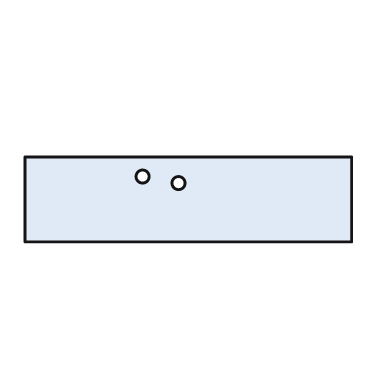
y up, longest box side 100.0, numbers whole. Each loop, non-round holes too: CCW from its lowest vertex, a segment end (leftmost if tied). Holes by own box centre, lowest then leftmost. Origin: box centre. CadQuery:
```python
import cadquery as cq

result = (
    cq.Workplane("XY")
    .moveTo(-50.0, -13.0)
    .lineTo(50.0, -13.0)
    .lineTo(50.0, 13.0)
    .lineTo(-50.0, 13.0)
    .close()
    .moveTo(-3.0, 5.0)
    .circle(2.0)
    .moveTo(-14.0, 7.0)
    .circle(2.0)
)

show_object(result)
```